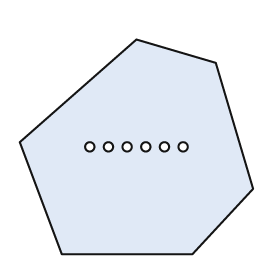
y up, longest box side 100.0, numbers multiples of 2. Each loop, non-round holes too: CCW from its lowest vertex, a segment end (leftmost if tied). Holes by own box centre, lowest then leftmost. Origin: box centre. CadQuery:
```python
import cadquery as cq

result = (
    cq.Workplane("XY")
    .moveTo(-32.0, -46.0)
    .lineTo(24.0, -46.0)
    .lineTo(50.0, -18.0)
    .lineTo(34.0, 36.0)
    .lineTo(0.0, 46.0)
    .lineTo(-50.0, 2.0)
    .close()
    .moveTo(-20.0, 0.0)
    .circle(2.0)
    .moveTo(-12.0, 0.0)
    .circle(2.0)
    .moveTo(-4.0, 0.0)
    .circle(2.0)
    .moveTo(4.0, 0.0)
    .circle(2.0)
    .moveTo(12.0, 0.0)
    .circle(2.0)
    .moveTo(20.0, 0.0)
    .circle(2.0)
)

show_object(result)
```